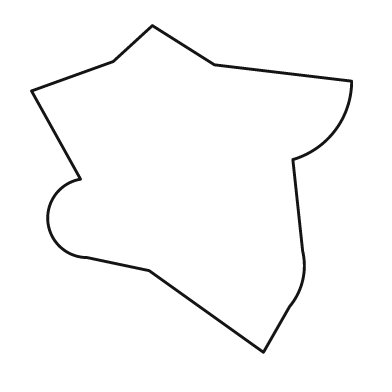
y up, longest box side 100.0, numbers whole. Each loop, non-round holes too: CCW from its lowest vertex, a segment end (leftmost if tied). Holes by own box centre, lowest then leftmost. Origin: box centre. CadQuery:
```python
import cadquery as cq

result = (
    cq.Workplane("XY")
    .moveTo(22.0, -50.0)
    .lineTo(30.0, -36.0)
    .threePointArc((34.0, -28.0), (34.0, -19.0))
    .lineTo(31.0, 9.0)
    .threePointArc((44.0, 18.0), (49.0, 33.0))
    .lineTo(7.0, 38.0)
    .lineTo(-12.0, 50.0)
    .lineTo(-24.0, 39.0)
    .lineTo(-49.0, 30.0)
    .lineTo(-34.0, 3.0)
    .threePointArc((-44.0, -10.0), (-32.0, -21.0))
    .lineTo(-13.0, -25.0)
    .close()
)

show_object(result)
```